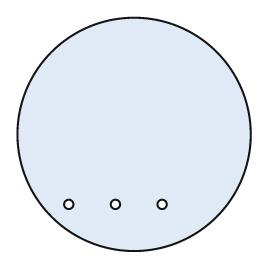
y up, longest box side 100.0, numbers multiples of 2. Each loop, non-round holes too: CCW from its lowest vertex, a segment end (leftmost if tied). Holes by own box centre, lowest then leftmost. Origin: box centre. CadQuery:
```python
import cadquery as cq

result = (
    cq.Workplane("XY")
    .moveTo(0.0, 0.0)
    .circle(50.0)
    .moveTo(-28.0, -30.0)
    .circle(2.0)
    .moveTo(-8.0, -30.0)
    .circle(2.0)
    .moveTo(12.0, -30.0)
    .circle(2.0)
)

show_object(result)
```